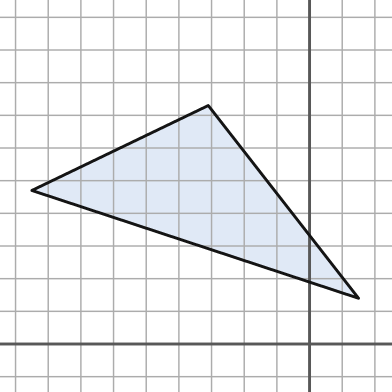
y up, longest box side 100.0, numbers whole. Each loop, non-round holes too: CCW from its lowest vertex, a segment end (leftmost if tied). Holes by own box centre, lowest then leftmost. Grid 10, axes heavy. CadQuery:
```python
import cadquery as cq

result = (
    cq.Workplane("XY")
    .moveTo(15.0, 14.0)
    .lineTo(-31.0, 73.0)
    .lineTo(-85.0, 47.0)
    .close()
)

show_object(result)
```